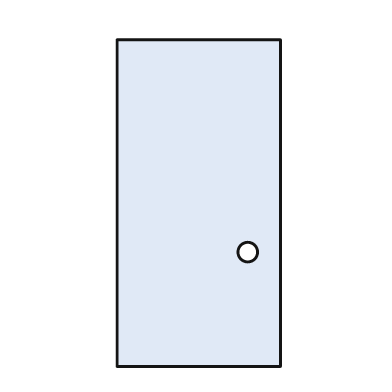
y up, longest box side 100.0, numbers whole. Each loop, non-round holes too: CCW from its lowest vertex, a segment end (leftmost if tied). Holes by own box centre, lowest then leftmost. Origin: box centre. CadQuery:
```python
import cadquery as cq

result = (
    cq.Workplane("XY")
    .moveTo(-25.0, -50.0)
    .lineTo(25.0, -50.0)
    .lineTo(25.0, 50.0)
    .lineTo(-25.0, 50.0)
    .close()
    .moveTo(15.0, -15.0)
    .circle(3.0)
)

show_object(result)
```